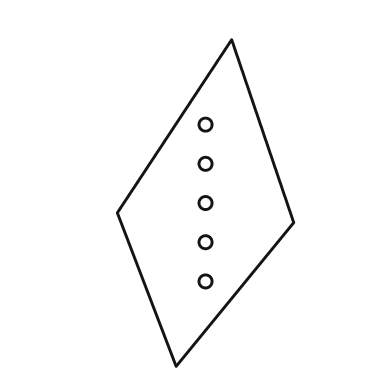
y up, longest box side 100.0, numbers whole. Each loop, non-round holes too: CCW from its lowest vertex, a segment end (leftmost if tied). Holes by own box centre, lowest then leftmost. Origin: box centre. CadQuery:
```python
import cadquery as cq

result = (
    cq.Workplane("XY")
    .moveTo(-9.0, -50.0)
    .lineTo(27.0, -6.0)
    .lineTo(8.0, 50.0)
    .lineTo(-27.0, -3.0)
    .close()
    .moveTo(0.0, -24.0)
    .circle(2.0)
    .moveTo(0.0, -12.0)
    .circle(2.0)
    .moveTo(0.0, 0.0)
    .circle(2.0)
    .moveTo(0.0, 12.0)
    .circle(2.0)
    .moveTo(0.0, 24.0)
    .circle(2.0)
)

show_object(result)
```